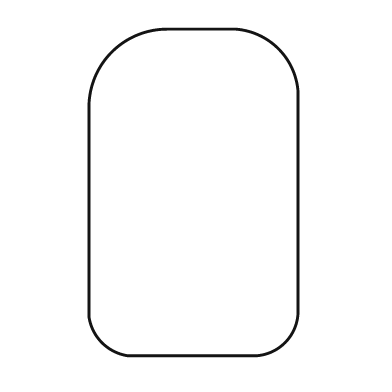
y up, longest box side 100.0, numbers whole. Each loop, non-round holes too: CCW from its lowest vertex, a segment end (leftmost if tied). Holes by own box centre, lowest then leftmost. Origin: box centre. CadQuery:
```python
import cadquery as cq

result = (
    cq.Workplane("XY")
    .moveTo(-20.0, -50.0)
    .lineTo(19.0, -50.0)
    .threePointArc((28.0, -46.0), (32.0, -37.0))
    .lineTo(32.0, 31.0)
    .threePointArc((26.0, 44.0), (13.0, 50.0))
    .lineTo(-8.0, 50.0)
    .threePointArc((-25.0, 43.0), (-32.0, 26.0))
    .lineTo(-32.0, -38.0)
    .threePointArc((-28.0, -46.0), (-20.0, -50.0))
    .close()
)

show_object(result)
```